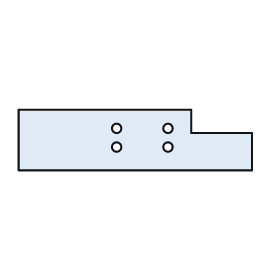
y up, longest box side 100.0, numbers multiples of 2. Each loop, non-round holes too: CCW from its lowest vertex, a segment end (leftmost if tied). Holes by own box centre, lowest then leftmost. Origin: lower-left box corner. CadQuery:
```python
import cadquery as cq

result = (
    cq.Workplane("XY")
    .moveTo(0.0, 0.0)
    .lineTo(100.0, 0.0)
    .lineTo(100.0, 16.0)
    .lineTo(74.0, 16.0)
    .lineTo(74.0, 26.0)
    .lineTo(0.0, 26.0)
    .close()
    .moveTo(42.0, 10.0)
    .circle(2.0)
    .moveTo(64.0, 10.0)
    .circle(2.0)
    .moveTo(42.0, 18.0)
    .circle(2.0)
    .moveTo(64.0, 18.0)
    .circle(2.0)
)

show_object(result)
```